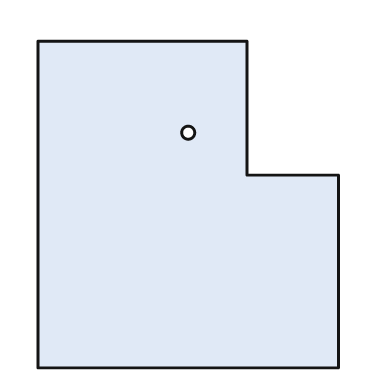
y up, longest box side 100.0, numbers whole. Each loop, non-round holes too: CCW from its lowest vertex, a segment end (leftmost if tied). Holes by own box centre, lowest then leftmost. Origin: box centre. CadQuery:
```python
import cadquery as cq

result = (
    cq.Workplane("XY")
    .moveTo(-46.0, -50.0)
    .lineTo(46.0, -50.0)
    .lineTo(46.0, 9.0)
    .lineTo(18.0, 9.0)
    .lineTo(18.0, 50.0)
    .lineTo(-46.0, 50.0)
    .close()
    .moveTo(0.0, 22.0)
    .circle(2.0)
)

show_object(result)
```